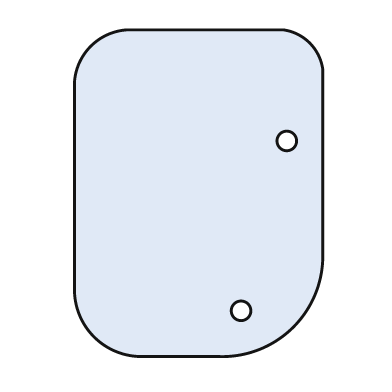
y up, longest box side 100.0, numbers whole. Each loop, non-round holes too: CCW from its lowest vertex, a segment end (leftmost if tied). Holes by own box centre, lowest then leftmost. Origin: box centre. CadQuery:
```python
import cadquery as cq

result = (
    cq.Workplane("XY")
    .moveTo(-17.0, -50.0)
    .lineTo(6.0, -50.0)
    .threePointArc((29.0, -41.0), (38.0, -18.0))
    .lineTo(38.0, 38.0)
    .threePointArc((34.0, 46.0), (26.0, 50.0))
    .lineTo(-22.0, 50.0)
    .threePointArc((-33.0, 45.0), (-38.0, 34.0))
    .lineTo(-38.0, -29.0)
    .threePointArc((-32.0, -44.0), (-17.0, -50.0))
    .close()
    .moveTo(13.0, -36.0)
    .circle(3.0)
    .moveTo(27.0, 16.0)
    .circle(3.0)
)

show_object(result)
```